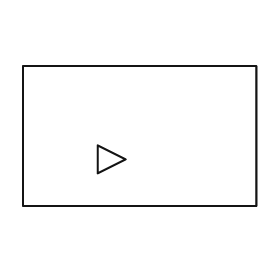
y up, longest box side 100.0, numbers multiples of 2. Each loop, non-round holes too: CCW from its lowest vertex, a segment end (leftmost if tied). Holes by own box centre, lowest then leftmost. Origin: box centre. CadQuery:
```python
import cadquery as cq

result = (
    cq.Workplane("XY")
    .moveTo(-50.0, -30.0)
    .lineTo(50.0, -30.0)
    .lineTo(50.0, 30.0)
    .lineTo(-50.0, 30.0)
    .close()
    .moveTo(-18.0, -16.0)
    .lineTo(-6.0, -10.0)
    .lineTo(-18.0, -4.0)
    .close()
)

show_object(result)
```